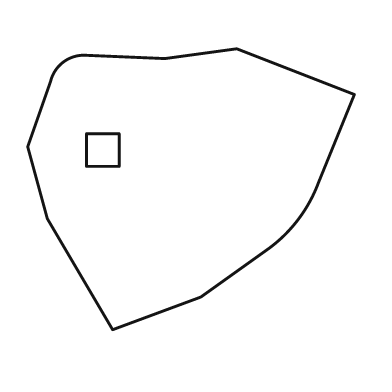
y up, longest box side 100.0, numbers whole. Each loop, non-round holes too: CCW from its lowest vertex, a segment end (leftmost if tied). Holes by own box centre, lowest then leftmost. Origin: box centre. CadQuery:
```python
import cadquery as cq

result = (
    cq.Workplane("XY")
    .moveTo(-24.0, -43.0)
    .lineTo(3.0, -33.0)
    .lineTo(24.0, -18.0)
    .threePointArc((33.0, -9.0), (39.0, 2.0))
    .lineTo(50.0, 29.0)
    .lineTo(14.0, 43.0)
    .lineTo(-8.0, 40.0)
    .lineTo(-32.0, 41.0)
    .threePointArc((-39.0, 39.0), (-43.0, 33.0))
    .lineTo(-50.0, 13.0)
    .lineTo(-44.0, -9.0)
    .close()
    .moveTo(-32.0, 7.0)
    .lineTo(-22.0, 7.0)
    .lineTo(-22.0, 17.0)
    .lineTo(-32.0, 17.0)
    .close()
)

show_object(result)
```